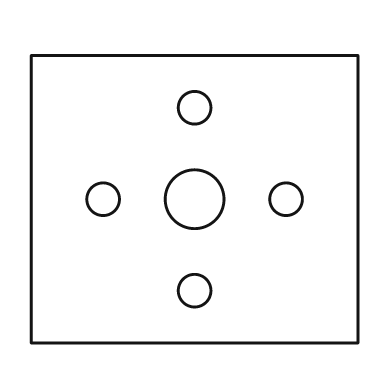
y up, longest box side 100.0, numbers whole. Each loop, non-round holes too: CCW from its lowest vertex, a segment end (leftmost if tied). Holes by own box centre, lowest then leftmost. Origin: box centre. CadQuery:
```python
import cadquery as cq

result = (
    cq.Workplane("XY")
    .moveTo(-50.0, -44.0)
    .lineTo(50.0, -44.0)
    .lineTo(50.0, 44.0)
    .lineTo(-50.0, 44.0)
    .close()
    .moveTo(0.0, -28.0)
    .circle(5.0)
    .moveTo(-28.0, 0.0)
    .circle(5.0)
    .moveTo(0.0, 0.0)
    .circle(9.0)
    .moveTo(28.0, 0.0)
    .circle(5.0)
    .moveTo(0.0, 28.0)
    .circle(5.0)
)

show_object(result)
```